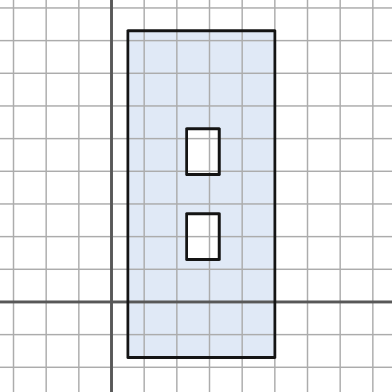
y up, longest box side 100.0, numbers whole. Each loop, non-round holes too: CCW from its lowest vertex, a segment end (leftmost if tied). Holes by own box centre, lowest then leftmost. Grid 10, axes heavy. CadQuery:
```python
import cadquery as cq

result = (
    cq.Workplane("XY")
    .moveTo(5.0, -17.0)
    .lineTo(50.0, -17.0)
    .lineTo(50.0, 83.0)
    .lineTo(5.0, 83.0)
    .close()
    .moveTo(23.0, 13.0)
    .lineTo(33.0, 13.0)
    .lineTo(33.0, 27.0)
    .lineTo(23.0, 27.0)
    .close()
    .moveTo(23.0, 39.0)
    .lineTo(33.0, 39.0)
    .lineTo(33.0, 53.0)
    .lineTo(23.0, 53.0)
    .close()
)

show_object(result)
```